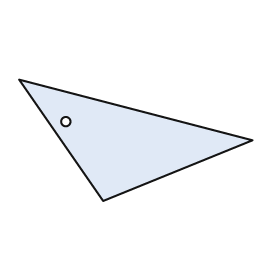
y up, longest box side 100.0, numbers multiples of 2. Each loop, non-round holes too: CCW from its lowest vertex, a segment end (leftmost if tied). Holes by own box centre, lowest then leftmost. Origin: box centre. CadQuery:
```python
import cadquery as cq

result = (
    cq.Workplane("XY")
    .moveTo(-14.0, -26.0)
    .lineTo(50.0, 0.0)
    .lineTo(-50.0, 26.0)
    .close()
    .moveTo(-30.0, 8.0)
    .circle(2.0)
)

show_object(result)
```